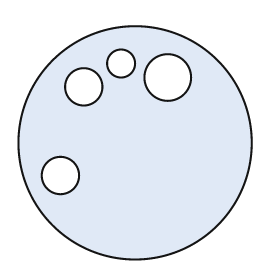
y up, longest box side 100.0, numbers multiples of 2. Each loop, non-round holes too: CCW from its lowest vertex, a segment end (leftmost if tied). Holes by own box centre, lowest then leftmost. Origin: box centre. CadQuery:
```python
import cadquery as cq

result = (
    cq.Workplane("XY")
    .moveTo(0.0, 0.0)
    .circle(50.0)
    .moveTo(-32.0, -14.0)
    .circle(8.0)
    .moveTo(-22.0, 24.0)
    .circle(8.0)
    .moveTo(14.0, 28.0)
    .circle(10.0)
    .moveTo(-6.0, 34.0)
    .circle(6.0)
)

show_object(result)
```